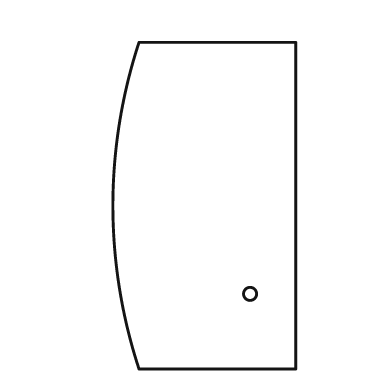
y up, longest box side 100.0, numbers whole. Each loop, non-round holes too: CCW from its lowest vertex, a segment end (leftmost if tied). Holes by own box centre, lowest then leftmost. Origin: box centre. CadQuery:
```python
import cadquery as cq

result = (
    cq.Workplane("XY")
    .moveTo(-20.0, -50.0)
    .lineTo(28.0, -50.0)
    .lineTo(28.0, 50.0)
    .lineTo(-20.0, 50.0)
    .threePointArc((-28.0, 0.0), (-20.0, -50.0))
    .close()
    .moveTo(14.0, -27.0)
    .circle(2.0)
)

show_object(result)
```